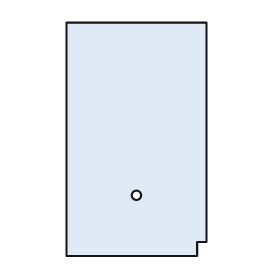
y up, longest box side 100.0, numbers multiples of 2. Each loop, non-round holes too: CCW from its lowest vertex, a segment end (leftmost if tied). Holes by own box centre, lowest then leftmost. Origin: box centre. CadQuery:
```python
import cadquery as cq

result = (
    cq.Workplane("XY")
    .moveTo(-30.0, -50.0)
    .lineTo(26.0, -50.0)
    .lineTo(26.0, -44.0)
    .lineTo(30.0, -44.0)
    .lineTo(30.0, 50.0)
    .lineTo(-30.0, 50.0)
    .close()
    .moveTo(0.0, -24.0)
    .circle(2.0)
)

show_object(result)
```